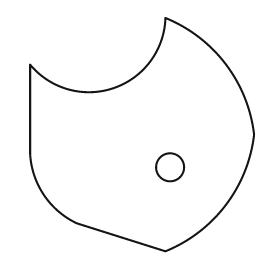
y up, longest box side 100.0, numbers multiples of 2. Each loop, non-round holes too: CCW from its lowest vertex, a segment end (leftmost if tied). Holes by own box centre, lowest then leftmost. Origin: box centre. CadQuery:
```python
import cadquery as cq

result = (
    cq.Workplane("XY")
    .moveTo(10.0, -50.0)
    .threePointArc((36.0, -30.0), (48.0, 0.0))
    .threePointArc((36.0, 30.0), (10.0, 50.0))
    .threePointArc((-12.0, 20.0), (-48.0, 30.0))
    .lineTo(-48.0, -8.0)
    .threePointArc((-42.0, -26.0), (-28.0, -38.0))
    .close()
    .moveTo(12.0, -14.0)
    .circle(6.0)
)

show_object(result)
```